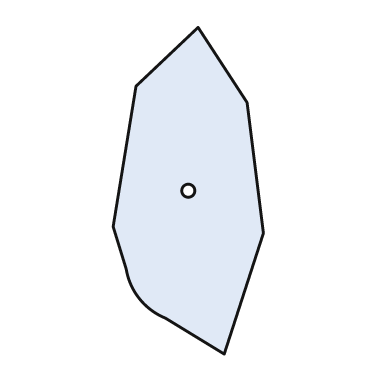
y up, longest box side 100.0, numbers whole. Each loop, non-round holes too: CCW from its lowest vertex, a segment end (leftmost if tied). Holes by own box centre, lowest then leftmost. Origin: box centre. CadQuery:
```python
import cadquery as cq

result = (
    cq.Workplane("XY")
    .moveTo(11.0, -50.0)
    .lineTo(23.0, -13.0)
    .lineTo(18.0, 27.0)
    .lineTo(3.0, 50.0)
    .lineTo(-16.0, 32.0)
    .lineTo(-23.0, -11.0)
    .lineTo(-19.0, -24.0)
    .threePointArc((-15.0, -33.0), (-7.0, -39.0))
    .close()
    .moveTo(0.0, 0.0)
    .circle(2.0)
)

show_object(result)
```